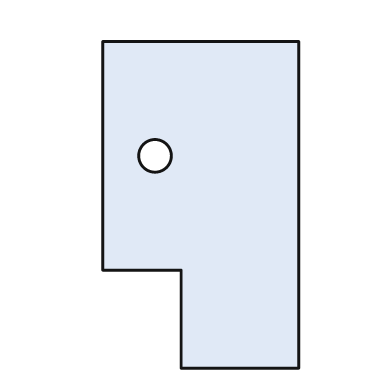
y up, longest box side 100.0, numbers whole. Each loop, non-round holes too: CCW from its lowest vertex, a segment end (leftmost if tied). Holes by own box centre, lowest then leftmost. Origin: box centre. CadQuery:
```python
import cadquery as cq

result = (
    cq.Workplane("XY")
    .moveTo(-6.0, -50.0)
    .lineTo(30.0, -50.0)
    .lineTo(30.0, 50.0)
    .lineTo(-30.0, 50.0)
    .lineTo(-30.0, -20.0)
    .lineTo(-6.0, -20.0)
    .close()
    .moveTo(-14.0, 15.0)
    .circle(5.0)
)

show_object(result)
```